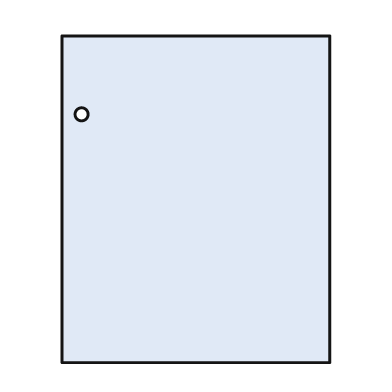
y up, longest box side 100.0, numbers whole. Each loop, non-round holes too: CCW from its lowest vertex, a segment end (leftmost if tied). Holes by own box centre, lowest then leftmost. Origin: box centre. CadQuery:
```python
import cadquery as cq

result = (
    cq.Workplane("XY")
    .moveTo(-41.0, -50.0)
    .lineTo(41.0, -50.0)
    .lineTo(41.0, 50.0)
    .lineTo(-41.0, 50.0)
    .close()
    .moveTo(-35.0, 26.0)
    .circle(2.0)
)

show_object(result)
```